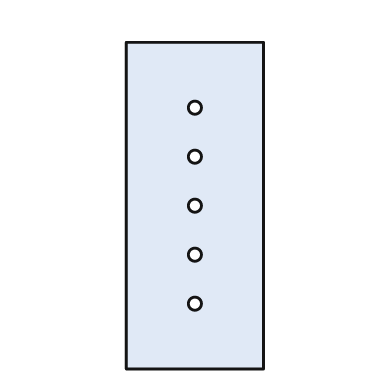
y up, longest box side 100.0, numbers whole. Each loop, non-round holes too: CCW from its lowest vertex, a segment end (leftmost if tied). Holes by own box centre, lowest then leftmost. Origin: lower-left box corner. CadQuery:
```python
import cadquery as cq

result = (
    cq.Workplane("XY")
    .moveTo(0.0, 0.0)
    .lineTo(42.0, 0.0)
    .lineTo(42.0, 100.0)
    .lineTo(0.0, 100.0)
    .close()
    .moveTo(21.0, 20.0)
    .circle(2.0)
    .moveTo(21.0, 35.0)
    .circle(2.0)
    .moveTo(21.0, 50.0)
    .circle(2.0)
    .moveTo(21.0, 65.0)
    .circle(2.0)
    .moveTo(21.0, 80.0)
    .circle(2.0)
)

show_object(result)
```